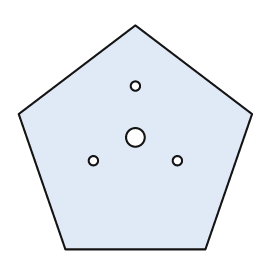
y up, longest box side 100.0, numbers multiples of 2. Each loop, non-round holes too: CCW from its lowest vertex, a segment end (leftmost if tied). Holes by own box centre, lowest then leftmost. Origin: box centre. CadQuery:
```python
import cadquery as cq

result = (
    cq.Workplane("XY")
    .moveTo(-30.0, -48.0)
    .lineTo(30.0, -48.0)
    .lineTo(50.0, 10.0)
    .lineTo(0.0, 48.0)
    .lineTo(-50.0, 10.0)
    .close()
    .moveTo(-18.0, -10.0)
    .circle(2.0)
    .moveTo(18.0, -10.0)
    .circle(2.0)
    .moveTo(0.0, 0.0)
    .circle(4.0)
    .moveTo(0.0, 22.0)
    .circle(2.0)
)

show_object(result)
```